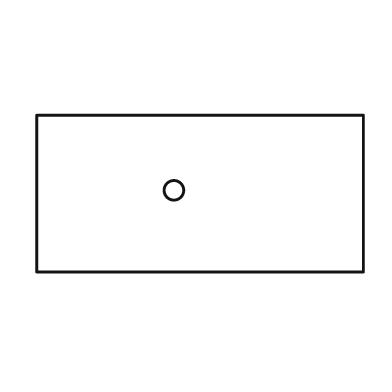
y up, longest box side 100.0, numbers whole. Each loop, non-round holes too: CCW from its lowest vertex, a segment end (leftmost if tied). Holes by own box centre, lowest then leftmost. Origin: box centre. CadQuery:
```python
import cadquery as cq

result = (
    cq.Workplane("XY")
    .moveTo(-50.0, -24.0)
    .lineTo(50.0, -24.0)
    .lineTo(50.0, 24.0)
    .lineTo(-50.0, 24.0)
    .close()
    .moveTo(-8.0, 1.0)
    .circle(3.0)
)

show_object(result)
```